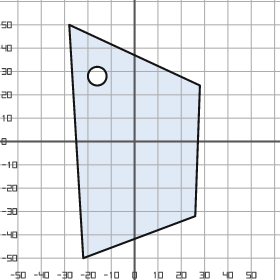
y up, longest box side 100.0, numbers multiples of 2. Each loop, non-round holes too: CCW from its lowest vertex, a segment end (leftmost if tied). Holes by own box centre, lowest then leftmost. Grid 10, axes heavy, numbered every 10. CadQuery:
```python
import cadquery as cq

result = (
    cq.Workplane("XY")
    .moveTo(-22.0, -50.0)
    .lineTo(26.0, -32.0)
    .lineTo(28.0, 24.0)
    .lineTo(-28.0, 50.0)
    .close()
    .moveTo(-16.0, 28.0)
    .circle(4.0)
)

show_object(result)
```